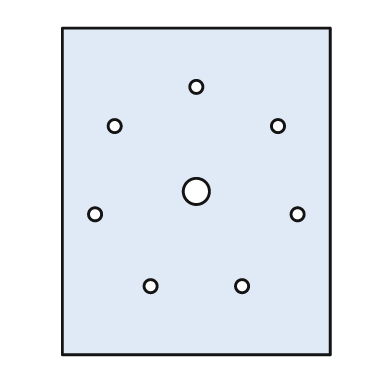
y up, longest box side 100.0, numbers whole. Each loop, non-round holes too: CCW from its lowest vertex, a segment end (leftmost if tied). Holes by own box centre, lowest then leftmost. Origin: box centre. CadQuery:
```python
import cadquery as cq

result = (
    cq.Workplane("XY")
    .moveTo(-41.0, -50.0)
    .lineTo(41.0, -50.0)
    .lineTo(41.0, 50.0)
    .lineTo(-41.0, 50.0)
    .close()
    .moveTo(-14.0, -29.0)
    .circle(2.0)
    .moveTo(14.0, -29.0)
    .circle(2.0)
    .moveTo(-31.0, -7.0)
    .circle(2.0)
    .moveTo(31.0, -7.0)
    .circle(2.0)
    .moveTo(0.0, 0.0)
    .circle(4.0)
    .moveTo(-25.0, 20.0)
    .circle(2.0)
    .moveTo(25.0, 20.0)
    .circle(2.0)
    .moveTo(0.0, 32.0)
    .circle(2.0)
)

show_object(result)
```